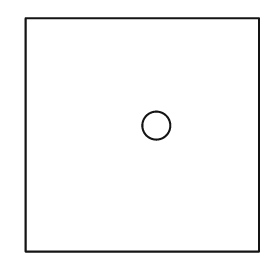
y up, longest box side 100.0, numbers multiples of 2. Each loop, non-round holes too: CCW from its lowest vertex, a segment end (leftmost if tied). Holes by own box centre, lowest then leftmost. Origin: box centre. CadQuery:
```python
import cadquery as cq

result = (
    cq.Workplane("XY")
    .moveTo(-50.0, -50.0)
    .lineTo(50.0, -50.0)
    .lineTo(50.0, 50.0)
    .lineTo(-50.0, 50.0)
    .close()
    .moveTo(6.0, 4.0)
    .circle(6.0)
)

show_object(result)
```